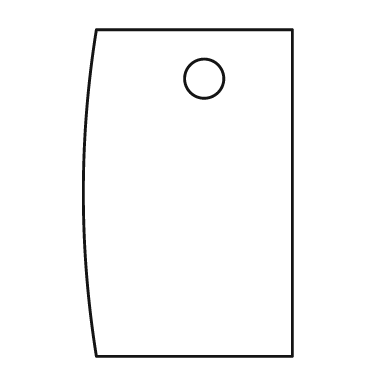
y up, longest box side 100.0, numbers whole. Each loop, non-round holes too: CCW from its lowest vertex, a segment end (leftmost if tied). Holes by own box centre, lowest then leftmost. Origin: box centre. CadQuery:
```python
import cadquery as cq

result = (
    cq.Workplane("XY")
    .moveTo(-28.0, -50.0)
    .lineTo(32.0, -50.0)
    .lineTo(32.0, 50.0)
    .lineTo(-28.0, 50.0)
    .threePointArc((-32.0, 0.0), (-28.0, -50.0))
    .close()
    .moveTo(5.0, 35.0)
    .circle(6.0)
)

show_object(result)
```